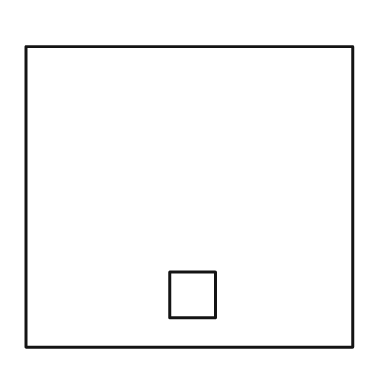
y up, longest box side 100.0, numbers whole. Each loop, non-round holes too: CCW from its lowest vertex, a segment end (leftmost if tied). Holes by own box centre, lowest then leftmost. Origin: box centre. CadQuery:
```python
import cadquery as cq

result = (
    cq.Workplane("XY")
    .moveTo(-50.0, -46.0)
    .lineTo(50.0, -46.0)
    .lineTo(50.0, 46.0)
    .lineTo(-50.0, 46.0)
    .close()
    .moveTo(-6.0, -37.0)
    .lineTo(8.0, -37.0)
    .lineTo(8.0, -23.0)
    .lineTo(-6.0, -23.0)
    .close()
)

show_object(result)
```